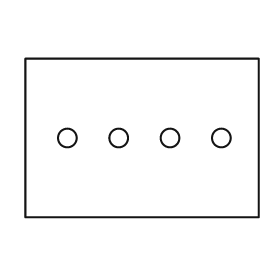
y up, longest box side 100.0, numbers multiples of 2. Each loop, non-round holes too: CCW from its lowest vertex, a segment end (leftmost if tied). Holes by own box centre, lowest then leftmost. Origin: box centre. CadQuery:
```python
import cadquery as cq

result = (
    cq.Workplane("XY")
    .moveTo(-50.0, -34.0)
    .lineTo(50.0, -34.0)
    .lineTo(50.0, 34.0)
    .lineTo(-50.0, 34.0)
    .close()
    .moveTo(-32.0, 0.0)
    .circle(4.0)
    .moveTo(-10.0, 0.0)
    .circle(4.0)
    .moveTo(12.0, 0.0)
    .circle(4.0)
    .moveTo(34.0, 0.0)
    .circle(4.0)
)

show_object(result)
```